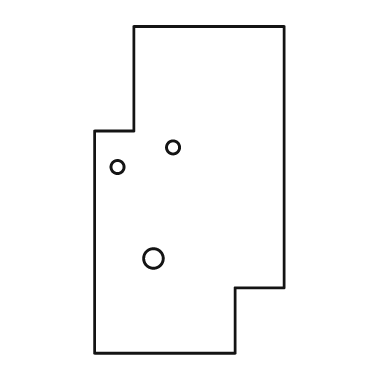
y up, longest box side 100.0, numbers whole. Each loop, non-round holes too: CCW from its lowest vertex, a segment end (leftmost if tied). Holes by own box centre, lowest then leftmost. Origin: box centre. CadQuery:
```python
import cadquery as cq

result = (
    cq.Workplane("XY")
    .moveTo(-29.0, -50.0)
    .lineTo(14.0, -50.0)
    .lineTo(14.0, -30.0)
    .lineTo(29.0, -30.0)
    .lineTo(29.0, 50.0)
    .lineTo(-17.0, 50.0)
    .lineTo(-17.0, 18.0)
    .lineTo(-29.0, 18.0)
    .close()
    .moveTo(-11.0, -21.0)
    .circle(3.0)
    .moveTo(-22.0, 7.0)
    .circle(2.0)
    .moveTo(-5.0, 13.0)
    .circle(2.0)
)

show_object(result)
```